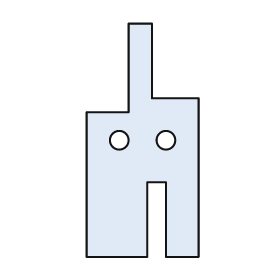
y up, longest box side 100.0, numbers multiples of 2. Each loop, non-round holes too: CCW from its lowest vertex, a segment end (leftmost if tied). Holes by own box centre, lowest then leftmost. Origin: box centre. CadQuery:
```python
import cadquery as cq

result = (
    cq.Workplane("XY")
    .moveTo(-24.0, -50.0)
    .lineTo(2.0, -50.0)
    .lineTo(2.0, -18.0)
    .lineTo(10.0, -18.0)
    .lineTo(10.0, -50.0)
    .lineTo(24.0, -50.0)
    .lineTo(24.0, 18.0)
    .lineTo(4.0, 18.0)
    .lineTo(4.0, 50.0)
    .lineTo(-6.0, 50.0)
    .lineTo(-6.0, 12.0)
    .lineTo(-24.0, 12.0)
    .close()
    .moveTo(-10.0, 0.0)
    .circle(4.0)
    .moveTo(10.0, 0.0)
    .circle(4.0)
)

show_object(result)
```